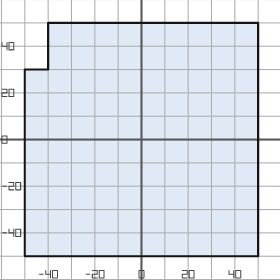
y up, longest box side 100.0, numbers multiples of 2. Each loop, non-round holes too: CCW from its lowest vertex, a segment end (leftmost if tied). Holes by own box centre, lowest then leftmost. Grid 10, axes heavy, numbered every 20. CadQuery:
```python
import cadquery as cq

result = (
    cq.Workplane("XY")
    .moveTo(-50.0, -50.0)
    .lineTo(50.0, -50.0)
    .lineTo(50.0, 50.0)
    .lineTo(-40.0, 50.0)
    .lineTo(-40.0, 30.0)
    .lineTo(-50.0, 30.0)
    .close()
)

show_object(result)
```